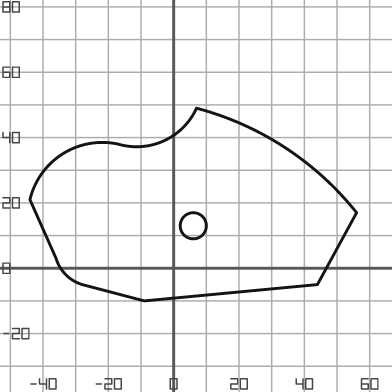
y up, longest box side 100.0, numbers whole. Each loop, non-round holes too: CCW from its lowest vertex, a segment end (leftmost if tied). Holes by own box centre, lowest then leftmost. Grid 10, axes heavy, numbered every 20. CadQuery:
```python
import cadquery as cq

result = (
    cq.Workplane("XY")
    .moveTo(-9.0, -10.0)
    .lineTo(44.0, -5.0)
    .lineTo(56.0, 17.0)
    .threePointArc((34.0, 37.0), (7.0, 49.0))
    .threePointArc((-3.0, 39.0), (-17.0, 38.0))
    .threePointArc((-34.0, 35.0), (-44.0, 21.0))
    .lineTo(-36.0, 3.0)
    .threePointArc((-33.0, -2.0), (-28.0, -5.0))
    .close()
    .moveTo(6.0, 13.0)
    .circle(4.0)
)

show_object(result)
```